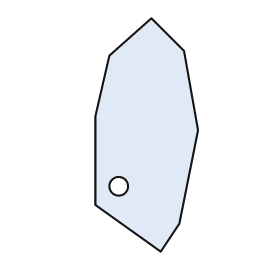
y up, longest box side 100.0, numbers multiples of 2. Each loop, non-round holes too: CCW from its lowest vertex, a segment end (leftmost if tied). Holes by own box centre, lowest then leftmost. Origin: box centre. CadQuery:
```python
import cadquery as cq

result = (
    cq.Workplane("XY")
    .moveTo(6.0, -50.0)
    .lineTo(14.0, -38.0)
    .lineTo(22.0, 2.0)
    .lineTo(16.0, 36.0)
    .lineTo(2.0, 50.0)
    .lineTo(-16.0, 34.0)
    .lineTo(-22.0, 8.0)
    .lineTo(-22.0, -30.0)
    .close()
    .moveTo(-12.0, -22.0)
    .circle(4.0)
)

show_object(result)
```